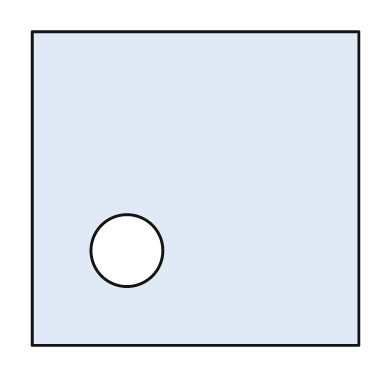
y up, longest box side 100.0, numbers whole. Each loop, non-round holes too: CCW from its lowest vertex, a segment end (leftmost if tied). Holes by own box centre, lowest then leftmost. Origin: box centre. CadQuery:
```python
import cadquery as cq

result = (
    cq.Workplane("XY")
    .moveTo(-50.0, -48.0)
    .lineTo(50.0, -48.0)
    .lineTo(50.0, 48.0)
    .lineTo(-50.0, 48.0)
    .close()
    .moveTo(-21.0, -19.0)
    .circle(11.0)
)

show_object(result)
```